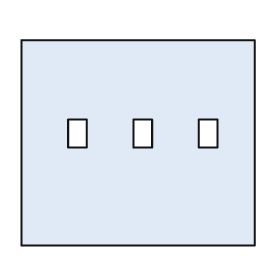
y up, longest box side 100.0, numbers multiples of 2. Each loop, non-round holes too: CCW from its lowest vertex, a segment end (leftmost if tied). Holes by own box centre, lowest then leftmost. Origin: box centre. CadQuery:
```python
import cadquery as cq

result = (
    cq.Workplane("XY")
    .moveTo(-50.0, -44.0)
    .lineTo(50.0, -44.0)
    .lineTo(50.0, 44.0)
    .lineTo(-50.0, 44.0)
    .close()
    .moveTo(-30.0, -2.0)
    .lineTo(-22.0, -2.0)
    .lineTo(-22.0, 10.0)
    .lineTo(-30.0, 10.0)
    .close()
    .moveTo(-2.0, -2.0)
    .lineTo(6.0, -2.0)
    .lineTo(6.0, 10.0)
    .lineTo(-2.0, 10.0)
    .close()
    .moveTo(26.0, -2.0)
    .lineTo(34.0, -2.0)
    .lineTo(34.0, 10.0)
    .lineTo(26.0, 10.0)
    .close()
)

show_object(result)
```